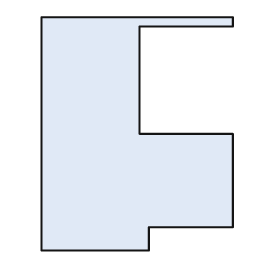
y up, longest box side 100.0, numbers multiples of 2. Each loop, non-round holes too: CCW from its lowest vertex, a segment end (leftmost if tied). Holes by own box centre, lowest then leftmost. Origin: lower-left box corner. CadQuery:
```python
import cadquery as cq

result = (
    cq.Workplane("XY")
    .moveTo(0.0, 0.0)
    .lineTo(46.0, 0.0)
    .lineTo(46.0, 10.0)
    .lineTo(82.0, 10.0)
    .lineTo(82.0, 50.0)
    .lineTo(42.0, 50.0)
    .lineTo(42.0, 96.0)
    .lineTo(82.0, 96.0)
    .lineTo(82.0, 100.0)
    .lineTo(0.0, 100.0)
    .close()
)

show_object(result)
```